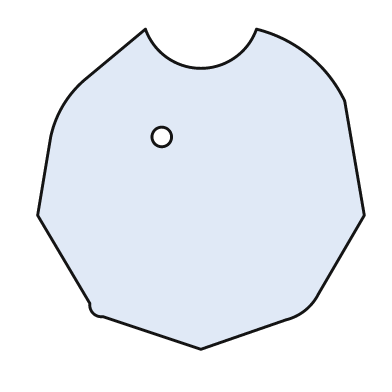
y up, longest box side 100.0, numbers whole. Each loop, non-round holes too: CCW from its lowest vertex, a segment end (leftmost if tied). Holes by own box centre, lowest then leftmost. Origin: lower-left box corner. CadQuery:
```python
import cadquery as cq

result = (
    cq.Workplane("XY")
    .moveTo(50.0, 0.0)
    .lineTo(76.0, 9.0)
    .threePointArc((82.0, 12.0), (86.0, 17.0))
    .lineTo(100.0, 41.0)
    .lineTo(94.0, 76.0)
    .threePointArc((83.0, 90.0), (67.0, 98.0))
    .threePointArc((50.0, 86.0), (33.0, 98.0))
    .lineTo(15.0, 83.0)
    .threePointArc((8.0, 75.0), (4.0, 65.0))
    .lineTo(0.0, 41.0)
    .lineTo(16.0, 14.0)
    .threePointArc((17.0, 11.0), (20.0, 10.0))
    .close()
    .moveTo(38.0, 65.0)
    .circle(3.0)
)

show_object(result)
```